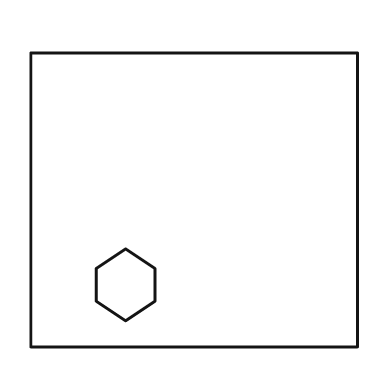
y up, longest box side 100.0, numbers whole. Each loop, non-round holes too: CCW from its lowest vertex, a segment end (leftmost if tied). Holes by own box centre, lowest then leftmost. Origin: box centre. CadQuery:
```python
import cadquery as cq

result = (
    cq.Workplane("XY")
    .moveTo(-50.0, -45.0)
    .lineTo(50.0, -45.0)
    .lineTo(50.0, 45.0)
    .lineTo(-50.0, 45.0)
    .close()
    .moveTo(-21.0, -37.0)
    .lineTo(-12.0, -31.0)
    .lineTo(-12.0, -21.0)
    .lineTo(-21.0, -15.0)
    .lineTo(-30.0, -21.0)
    .lineTo(-30.0, -31.0)
    .close()
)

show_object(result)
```